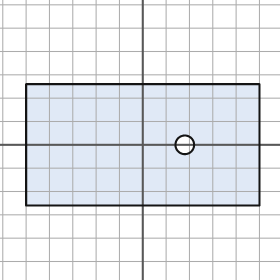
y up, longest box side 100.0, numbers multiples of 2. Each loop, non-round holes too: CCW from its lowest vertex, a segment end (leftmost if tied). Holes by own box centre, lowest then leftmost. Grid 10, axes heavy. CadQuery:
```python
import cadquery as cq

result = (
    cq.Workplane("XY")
    .moveTo(-50.0, -26.0)
    .lineTo(50.0, -26.0)
    .lineTo(50.0, 26.0)
    .lineTo(-50.0, 26.0)
    .close()
    .moveTo(18.0, 0.0)
    .circle(4.0)
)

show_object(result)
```